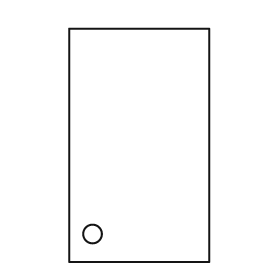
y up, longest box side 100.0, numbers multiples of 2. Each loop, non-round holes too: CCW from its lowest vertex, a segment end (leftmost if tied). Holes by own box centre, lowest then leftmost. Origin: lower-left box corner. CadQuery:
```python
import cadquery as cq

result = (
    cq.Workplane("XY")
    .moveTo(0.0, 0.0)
    .lineTo(60.0, 0.0)
    .lineTo(60.0, 100.0)
    .lineTo(0.0, 100.0)
    .close()
    .moveTo(10.0, 12.0)
    .circle(4.0)
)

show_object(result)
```